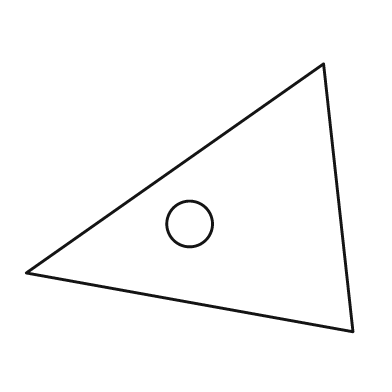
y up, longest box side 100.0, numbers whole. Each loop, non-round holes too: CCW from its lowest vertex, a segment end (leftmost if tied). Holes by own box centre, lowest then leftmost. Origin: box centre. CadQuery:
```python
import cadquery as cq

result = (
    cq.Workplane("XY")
    .moveTo(50.0, -41.0)
    .lineTo(41.0, 41.0)
    .lineTo(-50.0, -23.0)
    .close()
    .moveTo(0.0, -8.0)
    .circle(7.0)
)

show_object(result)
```